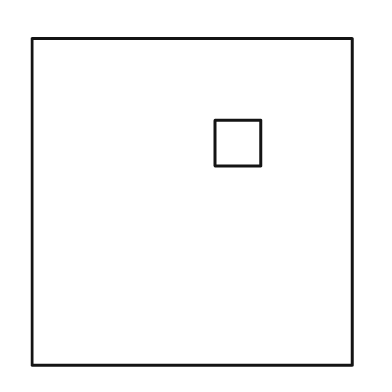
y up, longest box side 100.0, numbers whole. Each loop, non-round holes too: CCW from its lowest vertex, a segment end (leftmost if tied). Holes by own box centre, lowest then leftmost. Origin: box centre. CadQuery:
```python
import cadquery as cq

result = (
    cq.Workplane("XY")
    .moveTo(-49.0, -50.0)
    .lineTo(49.0, -50.0)
    .lineTo(49.0, 50.0)
    .lineTo(-49.0, 50.0)
    .close()
    .moveTo(7.0, 11.0)
    .lineTo(21.0, 11.0)
    .lineTo(21.0, 25.0)
    .lineTo(7.0, 25.0)
    .close()
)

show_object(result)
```